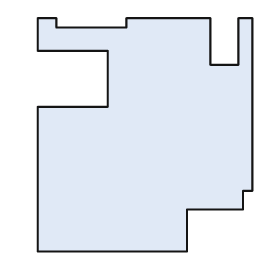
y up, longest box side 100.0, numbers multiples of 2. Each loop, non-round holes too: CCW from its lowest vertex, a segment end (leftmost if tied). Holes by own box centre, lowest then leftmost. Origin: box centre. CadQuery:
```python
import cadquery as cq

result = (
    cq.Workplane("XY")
    .moveTo(-46.0, -50.0)
    .lineTo(18.0, -50.0)
    .lineTo(18.0, -32.0)
    .lineTo(42.0, -32.0)
    .lineTo(42.0, -24.0)
    .lineTo(46.0, -24.0)
    .lineTo(46.0, 50.0)
    .lineTo(40.0, 50.0)
    .lineTo(40.0, 30.0)
    .lineTo(28.0, 30.0)
    .lineTo(28.0, 50.0)
    .lineTo(-8.0, 50.0)
    .lineTo(-8.0, 46.0)
    .lineTo(-38.0, 46.0)
    .lineTo(-38.0, 50.0)
    .lineTo(-46.0, 50.0)
    .lineTo(-46.0, 36.0)
    .lineTo(-16.0, 36.0)
    .lineTo(-16.0, 12.0)
    .lineTo(-46.0, 12.0)
    .close()
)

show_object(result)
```